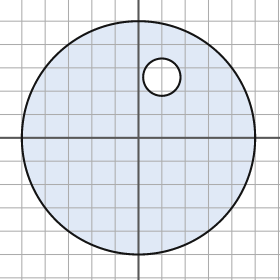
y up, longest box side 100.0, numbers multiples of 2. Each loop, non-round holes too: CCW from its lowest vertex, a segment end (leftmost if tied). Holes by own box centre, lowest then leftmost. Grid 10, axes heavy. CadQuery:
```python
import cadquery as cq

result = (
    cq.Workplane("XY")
    .moveTo(0.0, 0.0)
    .circle(50.0)
    .moveTo(10.0, 26.0)
    .circle(8.0)
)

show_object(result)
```